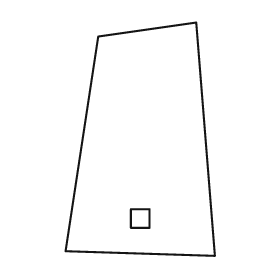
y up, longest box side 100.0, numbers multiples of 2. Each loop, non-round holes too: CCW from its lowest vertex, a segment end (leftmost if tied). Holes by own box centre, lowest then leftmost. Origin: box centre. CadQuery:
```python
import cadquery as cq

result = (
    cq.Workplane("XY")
    .moveTo(32.0, -50.0)
    .lineTo(24.0, 50.0)
    .lineTo(-18.0, 44.0)
    .lineTo(-32.0, -48.0)
    .close()
    .moveTo(-4.0, -38.0)
    .lineTo(4.0, -38.0)
    .lineTo(4.0, -30.0)
    .lineTo(-4.0, -30.0)
    .close()
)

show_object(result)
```